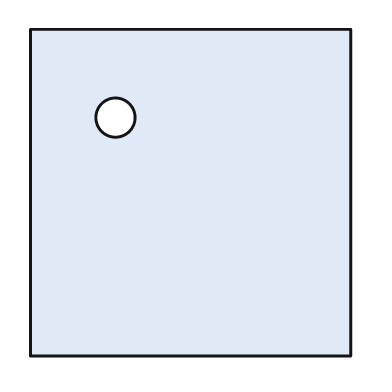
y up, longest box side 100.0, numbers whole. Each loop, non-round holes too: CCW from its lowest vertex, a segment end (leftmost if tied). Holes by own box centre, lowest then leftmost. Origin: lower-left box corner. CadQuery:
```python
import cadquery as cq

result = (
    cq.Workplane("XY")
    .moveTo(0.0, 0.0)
    .lineTo(98.0, 0.0)
    .lineTo(98.0, 100.0)
    .lineTo(0.0, 100.0)
    .close()
    .moveTo(26.0, 73.0)
    .circle(6.0)
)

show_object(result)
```